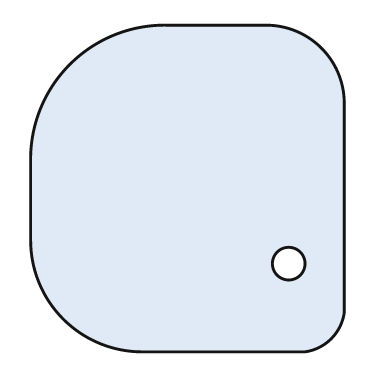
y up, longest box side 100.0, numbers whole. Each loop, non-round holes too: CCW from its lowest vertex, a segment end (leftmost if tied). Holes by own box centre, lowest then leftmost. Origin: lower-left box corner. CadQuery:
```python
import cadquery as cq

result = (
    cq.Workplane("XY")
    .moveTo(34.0, 0.0)
    .lineTo(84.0, 0.0)
    .threePointArc((92.0, 4.0), (96.0, 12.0))
    .lineTo(96.0, 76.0)
    .threePointArc((89.0, 93.0), (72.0, 100.0))
    .lineTo(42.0, 100.0)
    .threePointArc((12.0, 88.0), (0.0, 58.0))
    .lineTo(0.0, 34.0)
    .threePointArc((10.0, 10.0), (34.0, 0.0))
    .close()
    .moveTo(79.0, 27.0)
    .circle(5.0)
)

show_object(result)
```